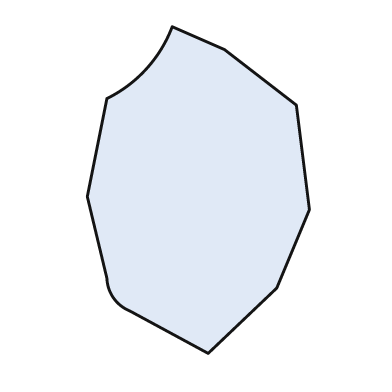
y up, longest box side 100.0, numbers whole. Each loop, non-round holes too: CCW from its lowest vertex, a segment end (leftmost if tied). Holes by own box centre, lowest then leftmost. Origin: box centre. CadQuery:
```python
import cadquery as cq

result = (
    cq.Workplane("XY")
    .moveTo(3.0, -50.0)
    .lineTo(24.0, -30.0)
    .lineTo(34.0, -6.0)
    .lineTo(30.0, 26.0)
    .lineTo(8.0, 43.0)
    .lineTo(-8.0, 50.0)
    .threePointArc((-16.0, 37.0), (-28.0, 28.0))
    .lineTo(-34.0, -2.0)
    .lineTo(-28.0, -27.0)
    .threePointArc((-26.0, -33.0), (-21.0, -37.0))
    .close()
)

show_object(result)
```